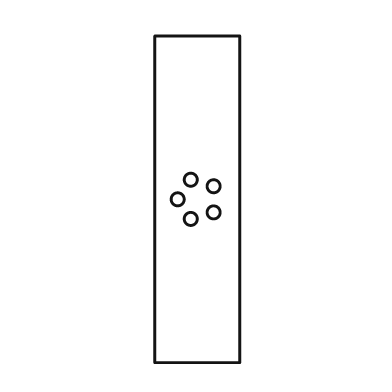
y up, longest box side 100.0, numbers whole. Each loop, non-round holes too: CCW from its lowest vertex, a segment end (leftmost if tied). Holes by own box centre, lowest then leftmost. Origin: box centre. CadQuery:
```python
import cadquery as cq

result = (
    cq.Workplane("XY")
    .moveTo(-13.0, -50.0)
    .lineTo(13.0, -50.0)
    .lineTo(13.0, 50.0)
    .lineTo(-13.0, 50.0)
    .close()
    .moveTo(-2.0, -6.0)
    .circle(2.0)
    .moveTo(5.0, -4.0)
    .circle(2.0)
    .moveTo(-6.0, 0.0)
    .circle(2.0)
    .moveTo(5.0, 4.0)
    .circle(2.0)
    .moveTo(-2.0, 6.0)
    .circle(2.0)
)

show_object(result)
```